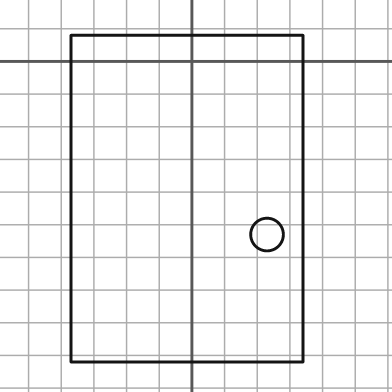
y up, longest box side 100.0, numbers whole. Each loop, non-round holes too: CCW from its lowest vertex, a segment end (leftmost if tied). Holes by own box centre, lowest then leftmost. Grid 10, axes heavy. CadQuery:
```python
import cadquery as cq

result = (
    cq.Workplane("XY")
    .moveTo(-37.0, -92.0)
    .lineTo(34.0, -92.0)
    .lineTo(34.0, 8.0)
    .lineTo(-37.0, 8.0)
    .close()
    .moveTo(23.0, -53.0)
    .circle(5.0)
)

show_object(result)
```